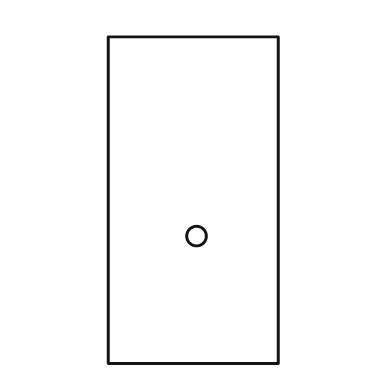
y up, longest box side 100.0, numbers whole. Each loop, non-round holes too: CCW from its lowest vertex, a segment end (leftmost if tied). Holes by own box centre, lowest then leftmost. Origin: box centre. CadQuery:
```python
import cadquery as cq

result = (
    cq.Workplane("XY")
    .moveTo(-26.0, -50.0)
    .lineTo(26.0, -50.0)
    .lineTo(26.0, 50.0)
    .lineTo(-26.0, 50.0)
    .close()
    .moveTo(1.0, -11.0)
    .circle(3.0)
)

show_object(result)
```